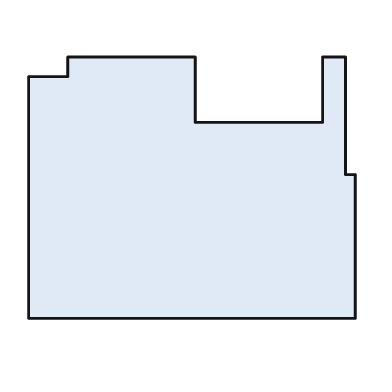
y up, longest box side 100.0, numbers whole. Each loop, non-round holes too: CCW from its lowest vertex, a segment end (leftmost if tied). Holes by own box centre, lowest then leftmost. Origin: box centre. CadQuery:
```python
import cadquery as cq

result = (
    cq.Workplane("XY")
    .moveTo(-50.0, -40.0)
    .lineTo(50.0, -40.0)
    .lineTo(50.0, 4.0)
    .lineTo(47.0, 4.0)
    .lineTo(47.0, 40.0)
    .lineTo(40.0, 40.0)
    .lineTo(40.0, 20.0)
    .lineTo(1.0, 20.0)
    .lineTo(1.0, 40.0)
    .lineTo(-38.0, 40.0)
    .lineTo(-38.0, 34.0)
    .lineTo(-50.0, 34.0)
    .close()
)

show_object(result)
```